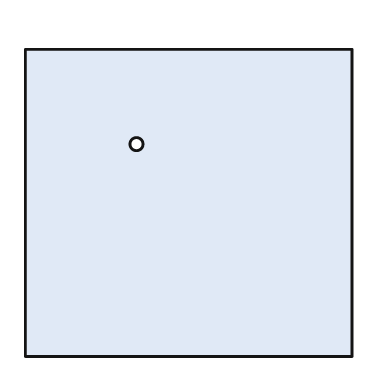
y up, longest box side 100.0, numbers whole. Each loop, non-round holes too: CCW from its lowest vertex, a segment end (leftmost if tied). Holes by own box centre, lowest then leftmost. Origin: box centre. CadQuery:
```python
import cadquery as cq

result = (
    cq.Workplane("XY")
    .moveTo(-50.0, -47.0)
    .lineTo(50.0, -47.0)
    .lineTo(50.0, 47.0)
    .lineTo(-50.0, 47.0)
    .close()
    .moveTo(-16.0, 18.0)
    .circle(2.0)
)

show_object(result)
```